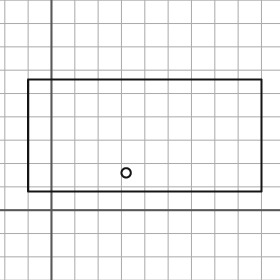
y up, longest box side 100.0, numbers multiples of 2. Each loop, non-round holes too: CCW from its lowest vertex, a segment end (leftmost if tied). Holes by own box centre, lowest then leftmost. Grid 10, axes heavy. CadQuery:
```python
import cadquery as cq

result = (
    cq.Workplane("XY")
    .moveTo(-10.0, 8.0)
    .lineTo(90.0, 8.0)
    .lineTo(90.0, 56.0)
    .lineTo(-10.0, 56.0)
    .close()
    .moveTo(32.0, 16.0)
    .circle(2.0)
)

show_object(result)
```